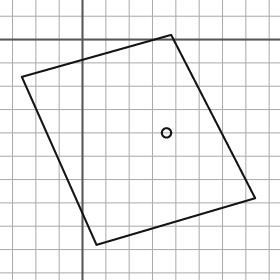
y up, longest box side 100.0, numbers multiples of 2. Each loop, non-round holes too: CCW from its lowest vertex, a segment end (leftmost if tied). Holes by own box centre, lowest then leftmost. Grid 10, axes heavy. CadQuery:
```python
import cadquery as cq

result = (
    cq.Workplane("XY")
    .moveTo(6.0, -88.0)
    .lineTo(74.0, -68.0)
    .lineTo(38.0, 2.0)
    .lineTo(-26.0, -16.0)
    .close()
    .moveTo(36.0, -40.0)
    .circle(2.0)
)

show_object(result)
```